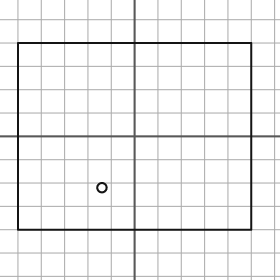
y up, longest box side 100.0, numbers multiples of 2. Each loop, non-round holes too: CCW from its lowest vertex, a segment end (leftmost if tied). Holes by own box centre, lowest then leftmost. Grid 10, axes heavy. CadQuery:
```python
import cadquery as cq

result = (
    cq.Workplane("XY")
    .moveTo(-50.0, -40.0)
    .lineTo(50.0, -40.0)
    .lineTo(50.0, 40.0)
    .lineTo(-50.0, 40.0)
    .close()
    .moveTo(-14.0, -22.0)
    .circle(2.0)
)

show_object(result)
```